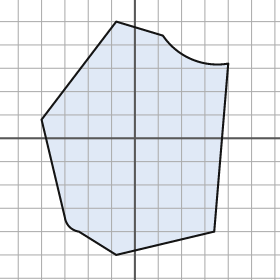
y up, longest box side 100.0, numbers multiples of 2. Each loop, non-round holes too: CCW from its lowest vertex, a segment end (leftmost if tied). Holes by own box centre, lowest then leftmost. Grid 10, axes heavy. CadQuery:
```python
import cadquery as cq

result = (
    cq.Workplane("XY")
    .moveTo(-8.0, -50.0)
    .lineTo(34.0, -40.0)
    .lineTo(40.0, 32.0)
    .threePointArc((24.0, 34.0), (12.0, 44.0))
    .lineTo(-8.0, 50.0)
    .lineTo(-40.0, 8.0)
    .lineTo(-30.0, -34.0)
    .threePointArc((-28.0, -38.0), (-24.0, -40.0))
    .close()
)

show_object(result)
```